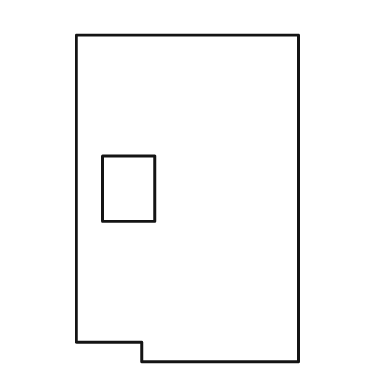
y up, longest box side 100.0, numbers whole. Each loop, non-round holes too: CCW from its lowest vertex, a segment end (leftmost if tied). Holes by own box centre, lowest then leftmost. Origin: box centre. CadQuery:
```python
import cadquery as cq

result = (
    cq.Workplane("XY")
    .moveTo(-14.0, -50.0)
    .lineTo(34.0, -50.0)
    .lineTo(34.0, 50.0)
    .lineTo(-34.0, 50.0)
    .lineTo(-34.0, -44.0)
    .lineTo(-14.0, -44.0)
    .close()
    .moveTo(-26.0, -7.0)
    .lineTo(-10.0, -7.0)
    .lineTo(-10.0, 13.0)
    .lineTo(-26.0, 13.0)
    .close()
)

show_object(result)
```